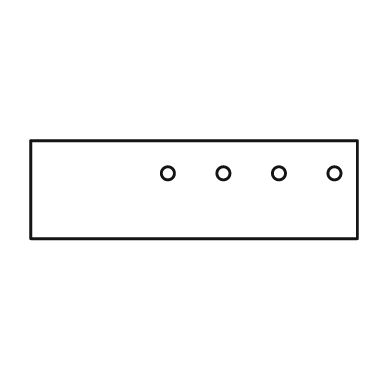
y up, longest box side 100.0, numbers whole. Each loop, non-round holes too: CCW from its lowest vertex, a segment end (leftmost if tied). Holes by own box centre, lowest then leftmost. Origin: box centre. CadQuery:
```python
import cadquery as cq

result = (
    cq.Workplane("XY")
    .moveTo(-50.0, -15.0)
    .lineTo(50.0, -15.0)
    .lineTo(50.0, 15.0)
    .lineTo(-50.0, 15.0)
    .close()
    .moveTo(-8.0, 5.0)
    .circle(2.0)
    .moveTo(9.0, 5.0)
    .circle(2.0)
    .moveTo(26.0, 5.0)
    .circle(2.0)
    .moveTo(43.0, 5.0)
    .circle(2.0)
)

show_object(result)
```